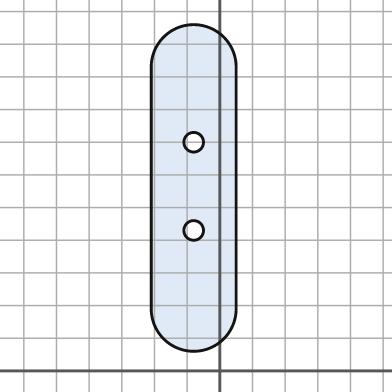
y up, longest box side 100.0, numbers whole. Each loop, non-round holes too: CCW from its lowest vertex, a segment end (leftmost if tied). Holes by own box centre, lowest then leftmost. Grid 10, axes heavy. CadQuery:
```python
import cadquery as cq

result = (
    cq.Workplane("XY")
    .moveTo(-21.0, 19.0)
    .threePointArc((-8.0, 6.0), (5.0, 19.0))
    .lineTo(5.0, 93.0)
    .threePointArc((-8.0, 106.0), (-21.0, 93.0))
    .close()
    .moveTo(-8.0, 43.0)
    .circle(3.0)
    .moveTo(-8.0, 70.0)
    .circle(3.0)
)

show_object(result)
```